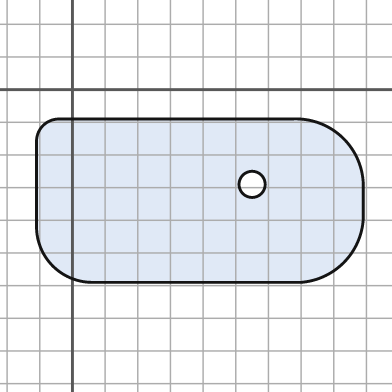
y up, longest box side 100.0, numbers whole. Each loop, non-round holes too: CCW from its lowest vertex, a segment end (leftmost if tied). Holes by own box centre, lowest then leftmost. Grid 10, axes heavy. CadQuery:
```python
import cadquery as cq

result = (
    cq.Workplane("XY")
    .moveTo(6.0, -59.0)
    .lineTo(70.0, -59.0)
    .threePointArc((83.0, -53.0), (89.0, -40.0))
    .lineTo(89.0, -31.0)
    .threePointArc((83.0, -15.0), (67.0, -9.0))
    .lineTo(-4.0, -9.0)
    .threePointArc((-9.0, -11.0), (-11.0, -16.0))
    .lineTo(-11.0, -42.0)
    .threePointArc((-6.0, -54.0), (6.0, -59.0))
    .close()
    .moveTo(55.0, -29.0)
    .circle(4.0)
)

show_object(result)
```